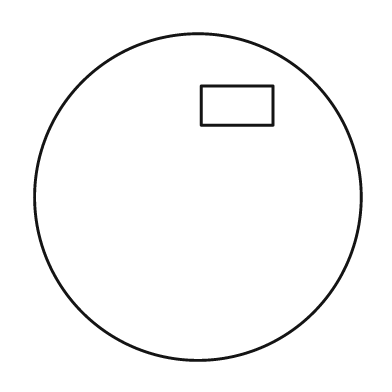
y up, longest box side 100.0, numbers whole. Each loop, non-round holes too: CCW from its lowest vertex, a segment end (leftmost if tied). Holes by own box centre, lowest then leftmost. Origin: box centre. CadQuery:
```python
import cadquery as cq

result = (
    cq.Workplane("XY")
    .moveTo(0.0, 0.0)
    .circle(50.0)
    .moveTo(1.0, 22.0)
    .lineTo(23.0, 22.0)
    .lineTo(23.0, 34.0)
    .lineTo(1.0, 34.0)
    .close()
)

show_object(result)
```